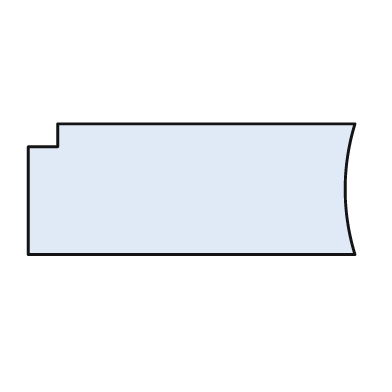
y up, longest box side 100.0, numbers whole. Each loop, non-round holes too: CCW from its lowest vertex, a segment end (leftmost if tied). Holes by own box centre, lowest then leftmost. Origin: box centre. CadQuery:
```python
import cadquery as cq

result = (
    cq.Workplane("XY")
    .moveTo(-50.0, -20.0)
    .lineTo(50.0, -20.0)
    .threePointArc((47.0, 0.0), (50.0, 20.0))
    .lineTo(-41.0, 20.0)
    .lineTo(-41.0, 13.0)
    .lineTo(-50.0, 13.0)
    .close()
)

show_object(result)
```